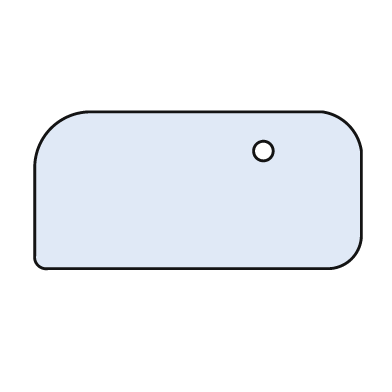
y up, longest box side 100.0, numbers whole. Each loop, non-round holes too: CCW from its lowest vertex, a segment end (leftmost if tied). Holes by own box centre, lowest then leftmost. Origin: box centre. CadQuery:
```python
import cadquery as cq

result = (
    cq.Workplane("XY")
    .moveTo(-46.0, -24.0)
    .lineTo(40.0, -24.0)
    .threePointArc((47.0, -21.0), (50.0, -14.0))
    .lineTo(50.0, 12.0)
    .threePointArc((46.0, 20.0), (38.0, 24.0))
    .lineTo(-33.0, 24.0)
    .threePointArc((-45.0, 19.0), (-50.0, 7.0))
    .lineTo(-50.0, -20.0)
    .threePointArc((-49.0, -23.0), (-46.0, -24.0))
    .close()
    .moveTo(20.0, 12.0)
    .circle(3.0)
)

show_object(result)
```